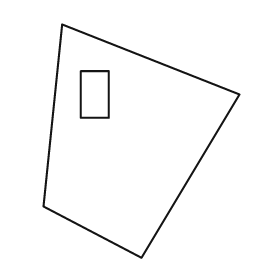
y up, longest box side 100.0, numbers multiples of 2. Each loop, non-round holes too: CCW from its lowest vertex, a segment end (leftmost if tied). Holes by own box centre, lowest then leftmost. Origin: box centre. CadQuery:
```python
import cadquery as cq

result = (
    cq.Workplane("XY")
    .moveTo(0.0, -50.0)
    .lineTo(42.0, 20.0)
    .lineTo(-34.0, 50.0)
    .lineTo(-42.0, -28.0)
    .close()
    .moveTo(-26.0, 10.0)
    .lineTo(-14.0, 10.0)
    .lineTo(-14.0, 30.0)
    .lineTo(-26.0, 30.0)
    .close()
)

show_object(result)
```